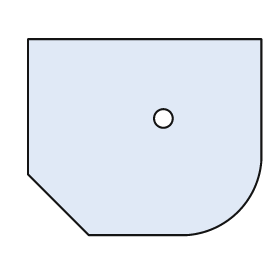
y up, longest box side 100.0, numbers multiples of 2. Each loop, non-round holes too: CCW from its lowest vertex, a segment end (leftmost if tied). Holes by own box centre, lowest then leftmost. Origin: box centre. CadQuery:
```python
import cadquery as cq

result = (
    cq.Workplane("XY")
    .moveTo(-24.0, -42.0)
    .lineTo(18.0, -42.0)
    .threePointArc((40.0, -32.0), (50.0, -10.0))
    .lineTo(50.0, 42.0)
    .lineTo(-50.0, 42.0)
    .lineTo(-50.0, -16.0)
    .close()
    .moveTo(8.0, 8.0)
    .circle(4.0)
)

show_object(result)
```